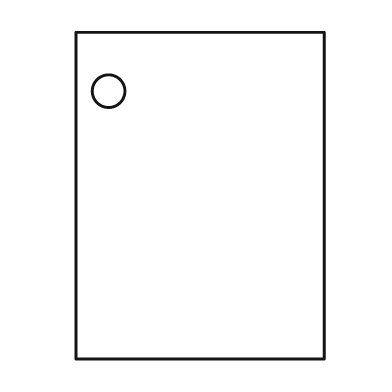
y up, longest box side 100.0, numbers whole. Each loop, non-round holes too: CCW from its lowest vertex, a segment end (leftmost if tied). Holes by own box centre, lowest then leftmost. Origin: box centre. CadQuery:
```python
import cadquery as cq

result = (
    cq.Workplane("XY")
    .moveTo(-38.0, -50.0)
    .lineTo(38.0, -50.0)
    .lineTo(38.0, 50.0)
    .lineTo(-38.0, 50.0)
    .close()
    .moveTo(-28.0, 32.0)
    .circle(5.0)
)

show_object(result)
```